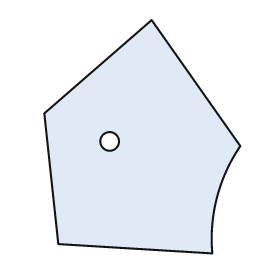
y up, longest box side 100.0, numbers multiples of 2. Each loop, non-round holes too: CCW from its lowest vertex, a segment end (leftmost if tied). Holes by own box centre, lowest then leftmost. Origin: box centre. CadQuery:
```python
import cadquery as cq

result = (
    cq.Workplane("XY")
    .moveTo(30.0, -50.0)
    .threePointArc((32.0, -26.0), (42.0, -4.0))
    .lineTo(4.0, 50.0)
    .lineTo(-42.0, 10.0)
    .lineTo(-36.0, -46.0)
    .close()
    .moveTo(-14.0, -2.0)
    .circle(4.0)
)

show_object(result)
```